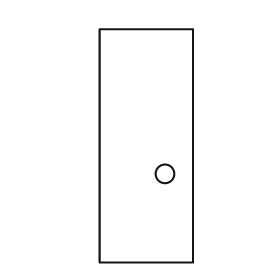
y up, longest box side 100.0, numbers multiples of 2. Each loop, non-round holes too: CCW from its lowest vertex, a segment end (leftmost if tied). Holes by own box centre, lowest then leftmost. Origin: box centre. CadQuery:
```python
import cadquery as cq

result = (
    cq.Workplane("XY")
    .moveTo(-20.0, -50.0)
    .lineTo(20.0, -50.0)
    .lineTo(20.0, 50.0)
    .lineTo(-20.0, 50.0)
    .close()
    .moveTo(8.0, -12.0)
    .circle(4.0)
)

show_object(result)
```